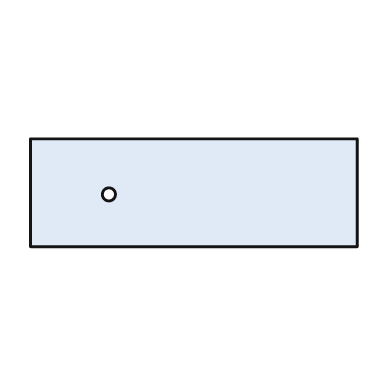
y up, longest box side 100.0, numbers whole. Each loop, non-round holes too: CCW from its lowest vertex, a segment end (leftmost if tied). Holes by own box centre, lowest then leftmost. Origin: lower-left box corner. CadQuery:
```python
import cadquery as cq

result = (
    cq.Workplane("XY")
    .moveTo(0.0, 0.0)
    .lineTo(100.0, 0.0)
    .lineTo(100.0, 33.0)
    .lineTo(0.0, 33.0)
    .close()
    .moveTo(24.0, 16.0)
    .circle(2.0)
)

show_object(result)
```